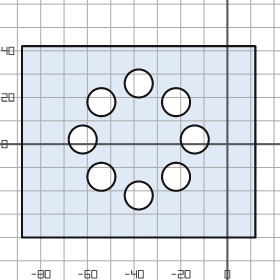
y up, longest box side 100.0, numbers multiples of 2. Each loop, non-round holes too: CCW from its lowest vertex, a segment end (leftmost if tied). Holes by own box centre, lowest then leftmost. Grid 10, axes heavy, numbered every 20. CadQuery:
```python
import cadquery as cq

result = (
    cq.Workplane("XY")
    .moveTo(-88.0, -40.0)
    .lineTo(12.0, -40.0)
    .lineTo(12.0, 42.0)
    .lineTo(-88.0, 42.0)
    .close()
    .moveTo(-38.0, -22.0)
    .circle(6.0)
    .moveTo(-54.0, -14.0)
    .circle(6.0)
    .moveTo(-22.0, -14.0)
    .circle(6.0)
    .moveTo(-62.0, 2.0)
    .circle(6.0)
    .moveTo(-14.0, 2.0)
    .circle(6.0)
    .moveTo(-54.0, 18.0)
    .circle(6.0)
    .moveTo(-22.0, 18.0)
    .circle(6.0)
    .moveTo(-38.0, 26.0)
    .circle(6.0)
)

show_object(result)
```